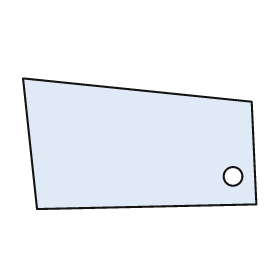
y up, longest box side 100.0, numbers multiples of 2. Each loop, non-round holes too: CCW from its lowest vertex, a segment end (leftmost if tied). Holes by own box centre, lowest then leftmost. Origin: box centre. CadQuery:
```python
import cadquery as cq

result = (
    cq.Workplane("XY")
    .moveTo(-44.0, -28.0)
    .lineTo(50.0, -26.0)
    .lineTo(48.0, 18.0)
    .lineTo(-50.0, 28.0)
    .close()
    .moveTo(40.0, -14.0)
    .circle(4.0)
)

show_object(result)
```